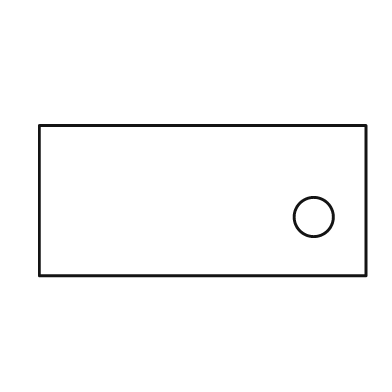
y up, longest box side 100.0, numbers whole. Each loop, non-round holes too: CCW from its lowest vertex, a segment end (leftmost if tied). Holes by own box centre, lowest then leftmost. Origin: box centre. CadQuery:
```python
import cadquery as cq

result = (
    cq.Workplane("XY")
    .moveTo(-50.0, -23.0)
    .lineTo(50.0, -23.0)
    .lineTo(50.0, 23.0)
    .lineTo(-50.0, 23.0)
    .close()
    .moveTo(34.0, -5.0)
    .circle(6.0)
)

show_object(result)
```